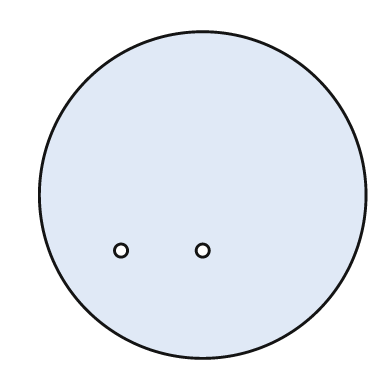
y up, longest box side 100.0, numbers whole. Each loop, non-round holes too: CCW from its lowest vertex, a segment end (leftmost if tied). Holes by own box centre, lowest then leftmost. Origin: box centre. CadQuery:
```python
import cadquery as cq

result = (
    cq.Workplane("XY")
    .moveTo(0.0, 0.0)
    .circle(50.0)
    .moveTo(-25.0, -17.0)
    .circle(2.0)
    .moveTo(0.0, -17.0)
    .circle(2.0)
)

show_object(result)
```